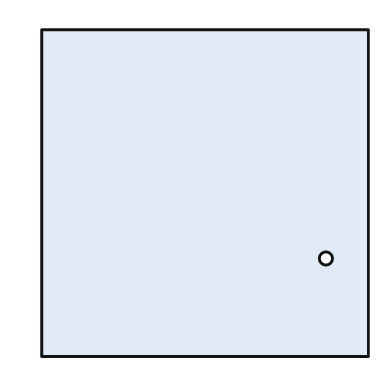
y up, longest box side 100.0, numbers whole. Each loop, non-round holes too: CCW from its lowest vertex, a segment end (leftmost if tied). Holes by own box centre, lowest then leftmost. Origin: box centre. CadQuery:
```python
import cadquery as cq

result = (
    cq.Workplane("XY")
    .moveTo(-50.0, -50.0)
    .lineTo(50.0, -50.0)
    .lineTo(50.0, 50.0)
    .lineTo(-50.0, 50.0)
    .close()
    .moveTo(37.0, -20.0)
    .circle(2.0)
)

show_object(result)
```